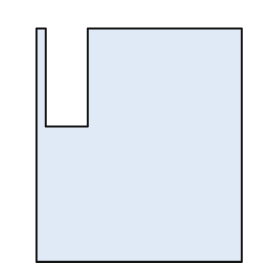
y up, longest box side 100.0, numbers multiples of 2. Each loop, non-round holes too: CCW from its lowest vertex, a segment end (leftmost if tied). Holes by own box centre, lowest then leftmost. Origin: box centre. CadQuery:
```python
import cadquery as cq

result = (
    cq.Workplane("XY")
    .moveTo(-44.0, -50.0)
    .lineTo(44.0, -50.0)
    .lineTo(44.0, 50.0)
    .lineTo(-22.0, 50.0)
    .lineTo(-22.0, 8.0)
    .lineTo(-40.0, 8.0)
    .lineTo(-40.0, 50.0)
    .lineTo(-44.0, 50.0)
    .close()
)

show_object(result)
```